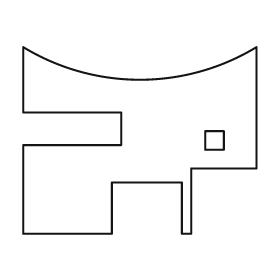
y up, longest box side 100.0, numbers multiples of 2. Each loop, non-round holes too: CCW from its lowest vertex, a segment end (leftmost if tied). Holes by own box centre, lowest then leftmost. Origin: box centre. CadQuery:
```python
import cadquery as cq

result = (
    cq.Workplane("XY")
    .moveTo(-50.0, -40.0)
    .lineTo(-12.0, -40.0)
    .lineTo(-12.0, -18.0)
    .lineTo(18.0, -18.0)
    .lineTo(18.0, -40.0)
    .lineTo(22.0, -40.0)
    .lineTo(22.0, -12.0)
    .lineTo(50.0, -12.0)
    .lineTo(50.0, 40.0)
    .threePointArc((0.0, 26.0), (-50.0, 40.0))
    .lineTo(-50.0, 12.0)
    .lineTo(-8.0, 12.0)
    .lineTo(-8.0, -2.0)
    .lineTo(-50.0, -2.0)
    .close()
    .moveTo(28.0, -4.0)
    .lineTo(36.0, -4.0)
    .lineTo(36.0, 4.0)
    .lineTo(28.0, 4.0)
    .close()
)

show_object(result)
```